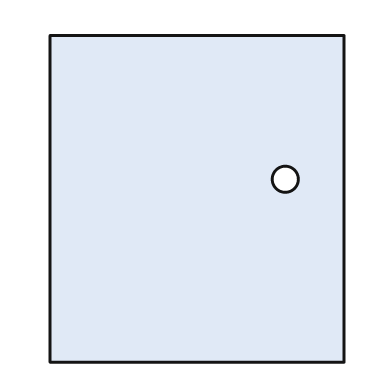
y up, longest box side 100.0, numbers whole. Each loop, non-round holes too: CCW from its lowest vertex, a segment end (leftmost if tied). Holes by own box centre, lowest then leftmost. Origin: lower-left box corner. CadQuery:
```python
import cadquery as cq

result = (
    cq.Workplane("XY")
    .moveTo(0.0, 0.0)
    .lineTo(90.0, 0.0)
    .lineTo(90.0, 100.0)
    .lineTo(0.0, 100.0)
    .close()
    .moveTo(72.0, 56.0)
    .circle(4.0)
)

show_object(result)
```